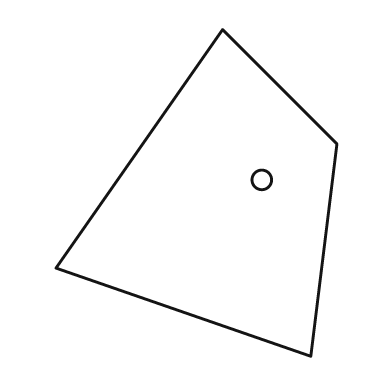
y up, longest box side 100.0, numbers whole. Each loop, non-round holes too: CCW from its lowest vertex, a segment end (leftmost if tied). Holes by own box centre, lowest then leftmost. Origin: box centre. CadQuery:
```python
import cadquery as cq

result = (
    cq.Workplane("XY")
    .moveTo(35.0, -50.0)
    .lineTo(43.0, 15.0)
    .lineTo(8.0, 50.0)
    .lineTo(-43.0, -23.0)
    .close()
    .moveTo(20.0, 4.0)
    .circle(3.0)
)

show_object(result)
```